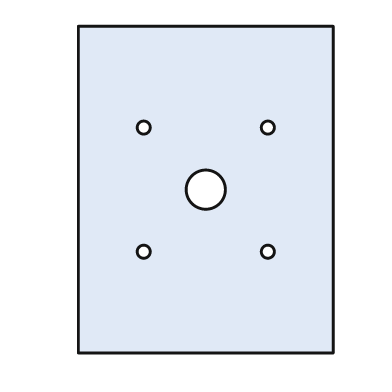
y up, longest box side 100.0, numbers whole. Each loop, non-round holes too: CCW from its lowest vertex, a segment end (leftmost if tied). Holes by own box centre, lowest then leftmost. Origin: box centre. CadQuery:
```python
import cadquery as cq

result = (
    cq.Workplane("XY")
    .moveTo(-39.0, -50.0)
    .lineTo(39.0, -50.0)
    .lineTo(39.0, 50.0)
    .lineTo(-39.0, 50.0)
    .close()
    .moveTo(-19.0, -19.0)
    .circle(2.0)
    .moveTo(19.0, -19.0)
    .circle(2.0)
    .moveTo(0.0, 0.0)
    .circle(6.0)
    .moveTo(-19.0, 19.0)
    .circle(2.0)
    .moveTo(19.0, 19.0)
    .circle(2.0)
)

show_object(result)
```